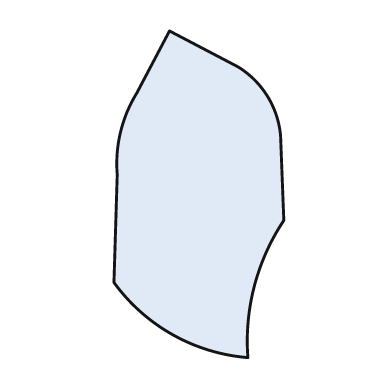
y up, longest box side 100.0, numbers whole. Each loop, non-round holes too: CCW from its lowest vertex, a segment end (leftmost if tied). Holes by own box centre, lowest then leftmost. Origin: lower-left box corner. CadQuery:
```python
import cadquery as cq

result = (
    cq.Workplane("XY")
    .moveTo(41.0, 0.0)
    .threePointArc((43.0, 22.0), (52.0, 42.0))
    .lineTo(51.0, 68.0)
    .threePointArc((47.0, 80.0), (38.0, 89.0))
    .lineTo(17.0, 100.0)
    .lineTo(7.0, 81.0)
    .threePointArc((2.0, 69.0), (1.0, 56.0))
    .lineTo(0.0, 23.0)
    .threePointArc((18.0, 7.0), (41.0, 0.0))
    .close()
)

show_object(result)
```